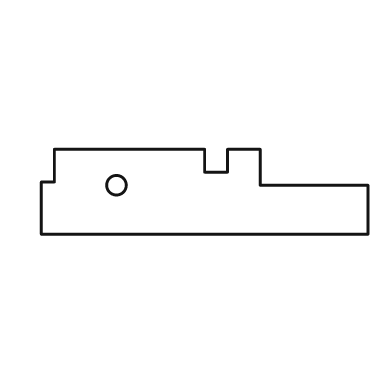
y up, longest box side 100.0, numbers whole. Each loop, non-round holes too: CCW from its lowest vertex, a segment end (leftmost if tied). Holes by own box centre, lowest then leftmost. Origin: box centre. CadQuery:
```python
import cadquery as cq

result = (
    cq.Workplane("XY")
    .moveTo(-50.0, -13.0)
    .lineTo(50.0, -13.0)
    .lineTo(50.0, 2.0)
    .lineTo(17.0, 2.0)
    .lineTo(17.0, 13.0)
    .lineTo(7.0, 13.0)
    .lineTo(7.0, 6.0)
    .lineTo(0.0, 6.0)
    .lineTo(0.0, 13.0)
    .lineTo(-46.0, 13.0)
    .lineTo(-46.0, 3.0)
    .lineTo(-50.0, 3.0)
    .close()
    .moveTo(-27.0, 2.0)
    .circle(3.0)
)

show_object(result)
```